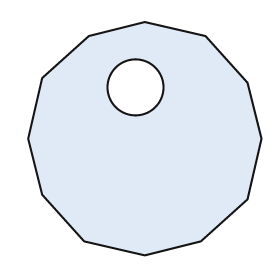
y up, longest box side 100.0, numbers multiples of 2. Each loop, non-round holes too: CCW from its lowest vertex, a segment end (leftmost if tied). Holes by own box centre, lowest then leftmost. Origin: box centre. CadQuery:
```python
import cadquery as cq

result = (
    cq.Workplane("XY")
    .moveTo(0.0, -50.0)
    .lineTo(24.0, -44.0)
    .lineTo(44.0, -26.0)
    .lineTo(50.0, 0.0)
    .lineTo(44.0, 24.0)
    .lineTo(26.0, 44.0)
    .lineTo(0.0, 50.0)
    .lineTo(-24.0, 44.0)
    .lineTo(-44.0, 26.0)
    .lineTo(-50.0, 0.0)
    .lineTo(-44.0, -24.0)
    .lineTo(-26.0, -44.0)
    .close()
    .moveTo(-4.0, 22.0)
    .circle(12.0)
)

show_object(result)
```